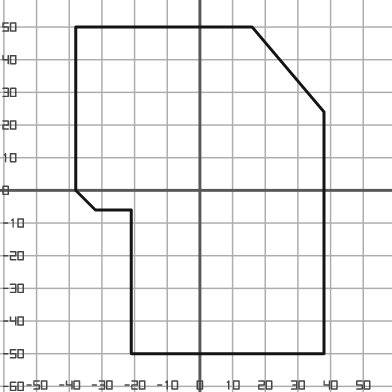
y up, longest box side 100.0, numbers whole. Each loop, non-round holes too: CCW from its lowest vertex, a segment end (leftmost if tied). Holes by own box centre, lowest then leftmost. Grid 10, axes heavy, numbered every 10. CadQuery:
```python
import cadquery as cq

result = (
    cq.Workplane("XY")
    .moveTo(-21.0, -50.0)
    .lineTo(38.0, -50.0)
    .lineTo(38.0, 24.0)
    .lineTo(16.0, 50.0)
    .lineTo(-38.0, 50.0)
    .lineTo(-38.0, 0.0)
    .lineTo(-32.0, -6.0)
    .lineTo(-21.0, -6.0)
    .close()
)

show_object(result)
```